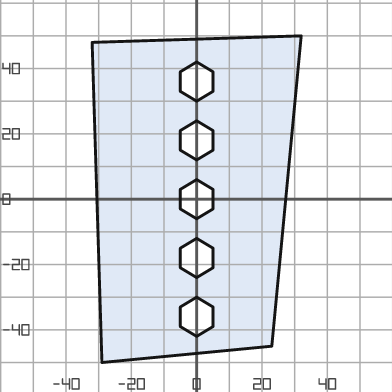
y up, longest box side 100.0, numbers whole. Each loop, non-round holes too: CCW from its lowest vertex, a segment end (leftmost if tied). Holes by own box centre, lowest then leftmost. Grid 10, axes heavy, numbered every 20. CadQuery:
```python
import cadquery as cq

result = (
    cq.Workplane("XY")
    .moveTo(-29.0, -50.0)
    .lineTo(23.0, -45.0)
    .lineTo(32.0, 50.0)
    .lineTo(-32.0, 48.0)
    .close()
    .moveTo(0.0, -42.0)
    .lineTo(5.0, -39.0)
    .lineTo(5.0, -33.0)
    .lineTo(0.0, -30.0)
    .lineTo(-5.0, -33.0)
    .lineTo(-5.0, -39.0)
    .close()
    .moveTo(0.0, -24.0)
    .lineTo(5.0, -21.0)
    .lineTo(5.0, -15.0)
    .lineTo(0.0, -12.0)
    .lineTo(-5.0, -15.0)
    .lineTo(-5.0, -21.0)
    .close()
    .moveTo(0.0, -6.0)
    .lineTo(5.0, -3.0)
    .lineTo(5.0, 3.0)
    .lineTo(0.0, 6.0)
    .lineTo(-5.0, 3.0)
    .lineTo(-5.0, -3.0)
    .close()
    .moveTo(0.0, 12.0)
    .lineTo(5.0, 15.0)
    .lineTo(5.0, 21.0)
    .lineTo(0.0, 24.0)
    .lineTo(-5.0, 21.0)
    .lineTo(-5.0, 15.0)
    .close()
    .moveTo(0.0, 30.0)
    .lineTo(5.0, 33.0)
    .lineTo(5.0, 39.0)
    .lineTo(0.0, 42.0)
    .lineTo(-5.0, 39.0)
    .lineTo(-5.0, 33.0)
    .close()
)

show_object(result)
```